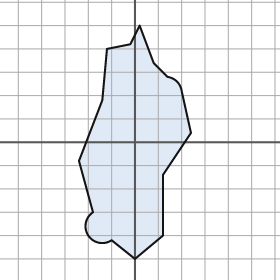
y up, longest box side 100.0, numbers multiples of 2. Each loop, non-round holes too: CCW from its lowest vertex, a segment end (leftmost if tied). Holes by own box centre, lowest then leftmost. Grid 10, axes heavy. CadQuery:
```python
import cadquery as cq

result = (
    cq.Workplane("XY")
    .moveTo(0.0, -50.0)
    .lineTo(12.0, -40.0)
    .lineTo(12.0, -14.0)
    .lineTo(24.0, 4.0)
    .lineTo(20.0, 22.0)
    .threePointArc((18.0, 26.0), (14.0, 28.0))
    .lineTo(8.0, 34.0)
    .lineTo(2.0, 50.0)
    .lineTo(-2.0, 42.0)
    .lineTo(-12.0, 40.0)
    .lineTo(-14.0, 18.0)
    .lineTo(-24.0, -8.0)
    .lineTo(-18.0, -30.0)
    .threePointArc((-20.0, -40.0), (-10.0, -42.0))
    .close()
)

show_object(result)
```